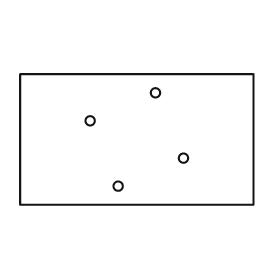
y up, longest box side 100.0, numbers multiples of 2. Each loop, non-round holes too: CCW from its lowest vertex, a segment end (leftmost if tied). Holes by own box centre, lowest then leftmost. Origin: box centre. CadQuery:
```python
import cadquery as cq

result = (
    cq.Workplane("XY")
    .moveTo(-50.0, -28.0)
    .lineTo(50.0, -28.0)
    .lineTo(50.0, 28.0)
    .lineTo(-50.0, 28.0)
    .close()
    .moveTo(-8.0, -20.0)
    .circle(2.0)
    .moveTo(20.0, -8.0)
    .circle(2.0)
    .moveTo(-20.0, 8.0)
    .circle(2.0)
    .moveTo(8.0, 20.0)
    .circle(2.0)
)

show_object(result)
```